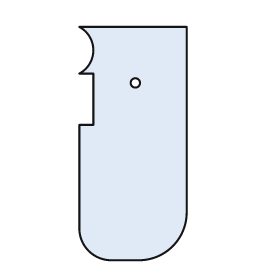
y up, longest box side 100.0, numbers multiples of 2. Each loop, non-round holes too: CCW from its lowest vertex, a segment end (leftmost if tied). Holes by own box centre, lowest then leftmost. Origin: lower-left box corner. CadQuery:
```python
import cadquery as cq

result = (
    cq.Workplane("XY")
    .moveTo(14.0, 0.0)
    .lineTo(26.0, 0.0)
    .threePointArc((40.0, 6.0), (46.0, 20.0))
    .lineTo(46.0, 100.0)
    .lineTo(0.0, 100.0)
    .threePointArc((6.0, 90.0), (0.0, 80.0))
    .lineTo(6.0, 80.0)
    .lineTo(6.0, 58.0)
    .lineTo(0.0, 58.0)
    .lineTo(0.0, 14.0)
    .threePointArc((4.0, 4.0), (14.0, 0.0))
    .close()
    .moveTo(24.0, 76.0)
    .circle(2.0)
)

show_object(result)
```